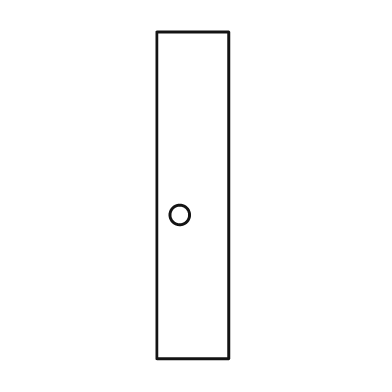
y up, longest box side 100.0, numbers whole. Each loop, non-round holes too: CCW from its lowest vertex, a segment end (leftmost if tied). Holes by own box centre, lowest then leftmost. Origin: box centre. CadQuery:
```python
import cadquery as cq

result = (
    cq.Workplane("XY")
    .moveTo(-11.0, -50.0)
    .lineTo(11.0, -50.0)
    .lineTo(11.0, 50.0)
    .lineTo(-11.0, 50.0)
    .close()
    .moveTo(-4.0, -6.0)
    .circle(3.0)
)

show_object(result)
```